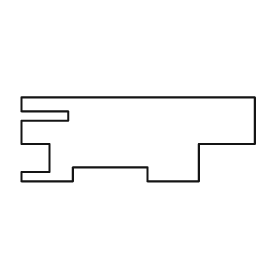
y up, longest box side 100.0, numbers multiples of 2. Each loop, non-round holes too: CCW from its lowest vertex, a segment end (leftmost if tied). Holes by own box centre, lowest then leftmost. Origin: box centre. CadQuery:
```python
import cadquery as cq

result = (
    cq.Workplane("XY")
    .moveTo(-50.0, -18.0)
    .lineTo(-28.0, -18.0)
    .lineTo(-28.0, -12.0)
    .lineTo(4.0, -12.0)
    .lineTo(4.0, -18.0)
    .lineTo(26.0, -18.0)
    .lineTo(26.0, -2.0)
    .lineTo(50.0, -2.0)
    .lineTo(50.0, 18.0)
    .lineTo(-50.0, 18.0)
    .lineTo(-50.0, 12.0)
    .lineTo(-30.0, 12.0)
    .lineTo(-30.0, 8.0)
    .lineTo(-50.0, 8.0)
    .lineTo(-50.0, -2.0)
    .lineTo(-38.0, -2.0)
    .lineTo(-38.0, -14.0)
    .lineTo(-50.0, -14.0)
    .close()
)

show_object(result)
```